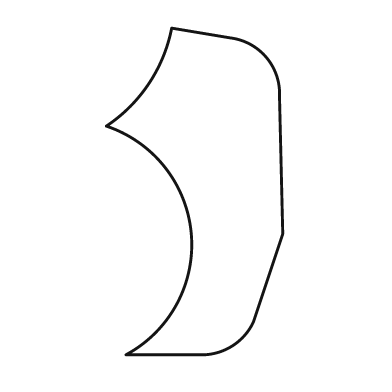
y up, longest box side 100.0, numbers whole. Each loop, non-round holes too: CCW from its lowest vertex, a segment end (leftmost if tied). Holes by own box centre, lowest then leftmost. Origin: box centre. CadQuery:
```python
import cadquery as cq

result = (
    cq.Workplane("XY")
    .moveTo(-21.0, -50.0)
    .lineTo(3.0, -50.0)
    .threePointArc((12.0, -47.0), (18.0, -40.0))
    .lineTo(27.0, -13.0)
    .lineTo(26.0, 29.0)
    .threePointArc((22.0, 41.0), (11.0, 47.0))
    .lineTo(-7.0, 50.0)
    .threePointArc((-14.0, 33.0), (-27.0, 20.0))
    .threePointArc((-1.0, -13.0), (-21.0, -50.0))
    .close()
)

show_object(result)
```